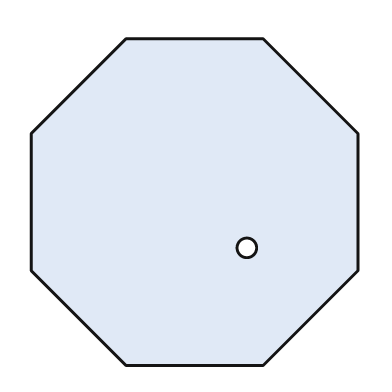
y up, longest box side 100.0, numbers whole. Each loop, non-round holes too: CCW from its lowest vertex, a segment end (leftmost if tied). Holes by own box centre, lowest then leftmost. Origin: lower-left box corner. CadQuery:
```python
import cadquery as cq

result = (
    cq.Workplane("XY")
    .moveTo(29.0, 0.0)
    .lineTo(71.0, 0.0)
    .lineTo(100.0, 29.0)
    .lineTo(100.0, 71.0)
    .lineTo(71.0, 100.0)
    .lineTo(29.0, 100.0)
    .lineTo(0.0, 71.0)
    .lineTo(0.0, 29.0)
    .close()
    .moveTo(66.0, 36.0)
    .circle(3.0)
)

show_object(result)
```